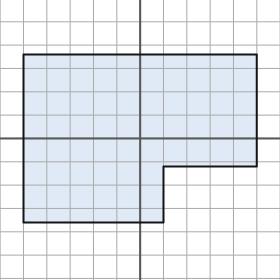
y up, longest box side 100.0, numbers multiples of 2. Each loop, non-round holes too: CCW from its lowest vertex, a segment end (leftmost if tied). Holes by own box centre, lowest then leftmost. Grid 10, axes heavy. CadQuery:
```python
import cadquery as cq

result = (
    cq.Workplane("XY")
    .moveTo(-50.0, -36.0)
    .lineTo(10.0, -36.0)
    .lineTo(10.0, -12.0)
    .lineTo(50.0, -12.0)
    .lineTo(50.0, 36.0)
    .lineTo(-50.0, 36.0)
    .close()
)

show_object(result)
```